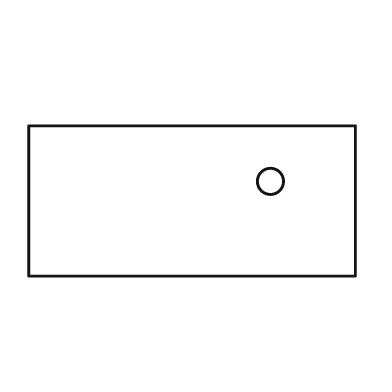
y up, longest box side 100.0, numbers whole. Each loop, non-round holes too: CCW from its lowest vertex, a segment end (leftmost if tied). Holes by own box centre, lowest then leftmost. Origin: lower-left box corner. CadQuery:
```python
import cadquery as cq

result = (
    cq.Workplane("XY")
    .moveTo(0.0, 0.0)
    .lineTo(100.0, 0.0)
    .lineTo(100.0, 46.0)
    .lineTo(0.0, 46.0)
    .close()
    .moveTo(74.0, 29.0)
    .circle(4.0)
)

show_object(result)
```